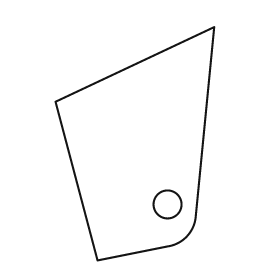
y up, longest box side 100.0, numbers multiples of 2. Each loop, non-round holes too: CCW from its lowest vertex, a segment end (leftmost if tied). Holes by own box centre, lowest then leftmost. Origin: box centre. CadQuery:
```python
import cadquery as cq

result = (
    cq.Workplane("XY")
    .moveTo(-16.0, -50.0)
    .lineTo(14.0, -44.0)
    .threePointArc((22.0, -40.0), (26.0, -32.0))
    .lineTo(34.0, 50.0)
    .lineTo(-34.0, 18.0)
    .close()
    .moveTo(14.0, -26.0)
    .circle(6.0)
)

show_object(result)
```